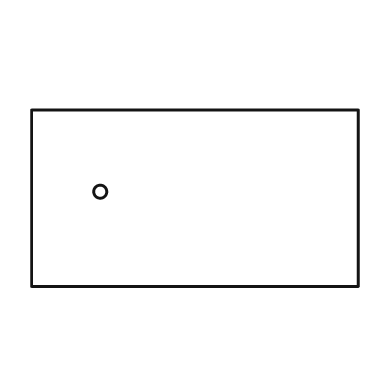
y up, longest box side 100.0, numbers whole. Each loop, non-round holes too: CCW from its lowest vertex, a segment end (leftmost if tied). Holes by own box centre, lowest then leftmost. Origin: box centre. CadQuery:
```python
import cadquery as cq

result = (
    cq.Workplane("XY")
    .moveTo(-50.0, -27.0)
    .lineTo(50.0, -27.0)
    .lineTo(50.0, 27.0)
    .lineTo(-50.0, 27.0)
    .close()
    .moveTo(-29.0, 2.0)
    .circle(2.0)
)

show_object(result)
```